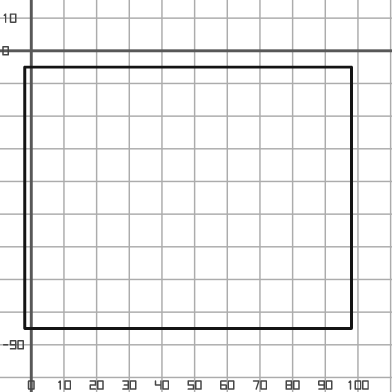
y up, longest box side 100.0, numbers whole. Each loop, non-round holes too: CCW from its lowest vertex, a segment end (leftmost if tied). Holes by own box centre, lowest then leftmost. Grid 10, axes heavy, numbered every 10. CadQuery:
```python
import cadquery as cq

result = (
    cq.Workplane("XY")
    .moveTo(-2.0, -85.0)
    .lineTo(98.0, -85.0)
    .lineTo(98.0, -5.0)
    .lineTo(-2.0, -5.0)
    .close()
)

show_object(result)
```